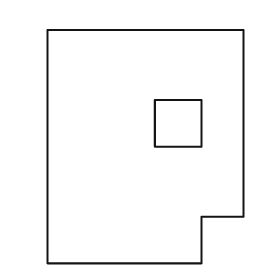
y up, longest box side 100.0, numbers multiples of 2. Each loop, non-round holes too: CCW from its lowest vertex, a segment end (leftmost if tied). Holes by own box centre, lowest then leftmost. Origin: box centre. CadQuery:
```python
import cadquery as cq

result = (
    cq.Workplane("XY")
    .moveTo(-42.0, -50.0)
    .lineTo(24.0, -50.0)
    .lineTo(24.0, -30.0)
    .lineTo(42.0, -30.0)
    .lineTo(42.0, 50.0)
    .lineTo(-42.0, 50.0)
    .close()
    .moveTo(4.0, 0.0)
    .lineTo(24.0, 0.0)
    .lineTo(24.0, 20.0)
    .lineTo(4.0, 20.0)
    .close()
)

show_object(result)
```